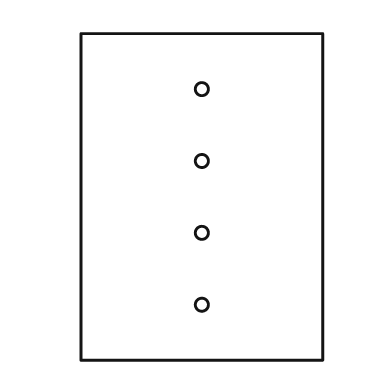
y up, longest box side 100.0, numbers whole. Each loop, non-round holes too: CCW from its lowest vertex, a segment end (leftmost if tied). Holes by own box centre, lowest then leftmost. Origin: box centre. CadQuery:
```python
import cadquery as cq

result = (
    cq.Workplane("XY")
    .moveTo(-37.0, -50.0)
    .lineTo(37.0, -50.0)
    .lineTo(37.0, 50.0)
    .lineTo(-37.0, 50.0)
    .close()
    .moveTo(0.0, -33.0)
    .circle(2.0)
    .moveTo(0.0, -11.0)
    .circle(2.0)
    .moveTo(0.0, 11.0)
    .circle(2.0)
    .moveTo(0.0, 33.0)
    .circle(2.0)
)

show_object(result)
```